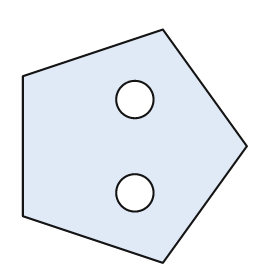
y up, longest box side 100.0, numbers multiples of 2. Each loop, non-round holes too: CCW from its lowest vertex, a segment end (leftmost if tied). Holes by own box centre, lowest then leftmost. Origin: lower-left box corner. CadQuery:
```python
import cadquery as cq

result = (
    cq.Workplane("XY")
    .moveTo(60.0, 0.0)
    .lineTo(96.0, 50.0)
    .lineTo(60.0, 100.0)
    .lineTo(0.0, 80.0)
    .lineTo(0.0, 20.0)
    .close()
    .moveTo(48.0, 30.0)
    .circle(8.0)
    .moveTo(48.0, 70.0)
    .circle(8.0)
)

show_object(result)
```